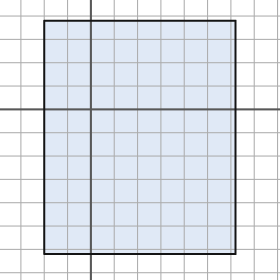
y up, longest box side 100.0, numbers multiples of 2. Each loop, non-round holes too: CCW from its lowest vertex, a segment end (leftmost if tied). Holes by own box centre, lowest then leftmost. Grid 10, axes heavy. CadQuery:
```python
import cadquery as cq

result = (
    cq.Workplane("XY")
    .moveTo(-20.0, -62.0)
    .lineTo(62.0, -62.0)
    .lineTo(62.0, 38.0)
    .lineTo(-20.0, 38.0)
    .close()
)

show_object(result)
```